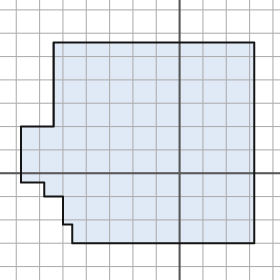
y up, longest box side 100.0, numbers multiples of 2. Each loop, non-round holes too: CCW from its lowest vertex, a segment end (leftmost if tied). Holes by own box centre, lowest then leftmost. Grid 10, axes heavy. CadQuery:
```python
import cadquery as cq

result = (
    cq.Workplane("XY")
    .moveTo(-46.0, -30.0)
    .lineTo(32.0, -30.0)
    .lineTo(32.0, 56.0)
    .lineTo(-54.0, 56.0)
    .lineTo(-54.0, 20.0)
    .lineTo(-68.0, 20.0)
    .lineTo(-68.0, -4.0)
    .lineTo(-58.0, -4.0)
    .lineTo(-58.0, -10.0)
    .lineTo(-50.0, -10.0)
    .lineTo(-50.0, -22.0)
    .lineTo(-46.0, -22.0)
    .close()
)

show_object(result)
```